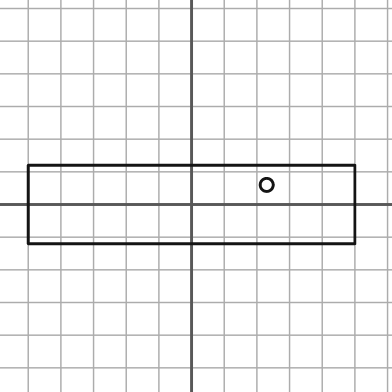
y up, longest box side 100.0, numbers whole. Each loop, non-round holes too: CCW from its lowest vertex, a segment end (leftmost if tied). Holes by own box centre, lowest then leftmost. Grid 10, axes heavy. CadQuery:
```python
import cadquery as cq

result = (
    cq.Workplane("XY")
    .moveTo(-50.0, -12.0)
    .lineTo(50.0, -12.0)
    .lineTo(50.0, 12.0)
    .lineTo(-50.0, 12.0)
    .close()
    .moveTo(23.0, 6.0)
    .circle(2.0)
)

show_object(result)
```